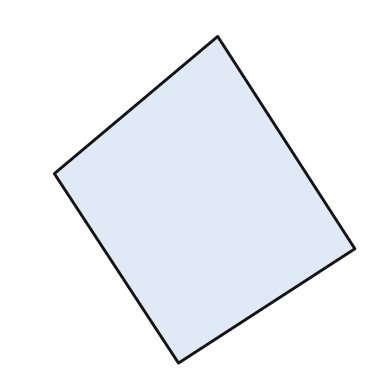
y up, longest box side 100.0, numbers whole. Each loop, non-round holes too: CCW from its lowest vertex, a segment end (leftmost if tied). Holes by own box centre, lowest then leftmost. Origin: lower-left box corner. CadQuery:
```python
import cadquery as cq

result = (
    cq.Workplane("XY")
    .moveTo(38.0, 0.0)
    .lineTo(92.0, 35.0)
    .lineTo(50.0, 100.0)
    .lineTo(0.0, 58.0)
    .close()
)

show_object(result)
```